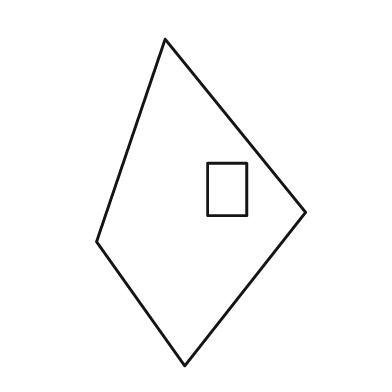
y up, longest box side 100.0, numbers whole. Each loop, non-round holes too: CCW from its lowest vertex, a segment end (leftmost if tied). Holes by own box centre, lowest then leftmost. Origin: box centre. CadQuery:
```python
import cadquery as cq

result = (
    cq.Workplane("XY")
    .moveTo(-5.0, -50.0)
    .lineTo(32.0, -3.0)
    .lineTo(-11.0, 50.0)
    .lineTo(-32.0, -12.0)
    .close()
    .moveTo(2.0, -4.0)
    .lineTo(14.0, -4.0)
    .lineTo(14.0, 12.0)
    .lineTo(2.0, 12.0)
    .close()
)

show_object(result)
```